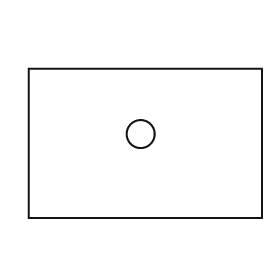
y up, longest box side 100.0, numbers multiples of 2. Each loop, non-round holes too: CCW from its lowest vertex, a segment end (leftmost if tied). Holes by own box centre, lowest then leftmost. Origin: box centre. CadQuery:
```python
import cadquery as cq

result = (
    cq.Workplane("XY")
    .moveTo(-50.0, -32.0)
    .lineTo(50.0, -32.0)
    .lineTo(50.0, 32.0)
    .lineTo(-50.0, 32.0)
    .close()
    .moveTo(-2.0, 4.0)
    .circle(6.0)
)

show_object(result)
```